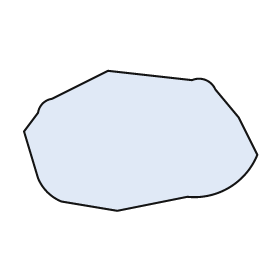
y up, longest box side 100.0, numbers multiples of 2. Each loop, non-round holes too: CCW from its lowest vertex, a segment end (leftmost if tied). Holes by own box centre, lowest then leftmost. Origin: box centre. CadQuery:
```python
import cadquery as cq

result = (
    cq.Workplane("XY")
    .moveTo(-10.0, -30.0)
    .lineTo(20.0, -24.0)
    .threePointArc((38.0, -20.0), (50.0, -6.0))
    .lineTo(42.0, 10.0)
    .lineTo(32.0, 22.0)
    .threePointArc((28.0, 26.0), (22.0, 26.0))
    .lineTo(-14.0, 30.0)
    .lineTo(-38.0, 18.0)
    .threePointArc((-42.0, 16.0), (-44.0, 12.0))
    .lineTo(-50.0, 4.0)
    .lineTo(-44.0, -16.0)
    .threePointArc((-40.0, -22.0), (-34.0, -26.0))
    .close()
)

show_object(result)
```